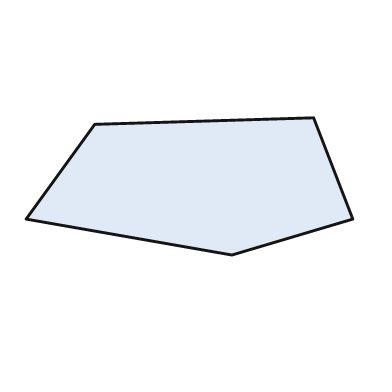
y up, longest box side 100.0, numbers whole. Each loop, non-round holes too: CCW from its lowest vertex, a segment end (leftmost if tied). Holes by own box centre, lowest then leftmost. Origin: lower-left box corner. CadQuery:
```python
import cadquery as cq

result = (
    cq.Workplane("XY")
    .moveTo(63.0, 0.0)
    .lineTo(100.0, 11.0)
    .lineTo(88.0, 42.0)
    .lineTo(21.0, 40.0)
    .lineTo(0.0, 11.0)
    .close()
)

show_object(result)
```